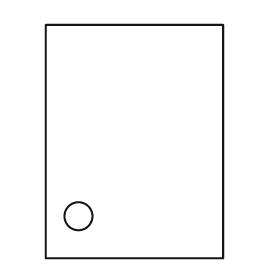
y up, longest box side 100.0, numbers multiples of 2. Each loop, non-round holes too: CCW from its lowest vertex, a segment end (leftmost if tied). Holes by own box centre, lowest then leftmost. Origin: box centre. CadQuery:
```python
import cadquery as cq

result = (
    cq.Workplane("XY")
    .moveTo(-38.0, -50.0)
    .lineTo(38.0, -50.0)
    .lineTo(38.0, 50.0)
    .lineTo(-38.0, 50.0)
    .close()
    .moveTo(-24.0, -32.0)
    .circle(6.0)
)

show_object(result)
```